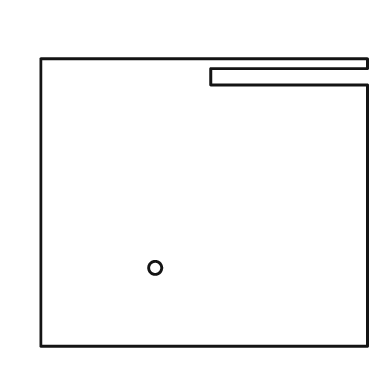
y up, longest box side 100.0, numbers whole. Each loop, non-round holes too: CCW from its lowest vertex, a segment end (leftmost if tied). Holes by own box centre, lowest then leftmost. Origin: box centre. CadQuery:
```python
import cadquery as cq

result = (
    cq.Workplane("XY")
    .moveTo(-50.0, -44.0)
    .lineTo(50.0, -44.0)
    .lineTo(50.0, 36.0)
    .lineTo(2.0, 36.0)
    .lineTo(2.0, 41.0)
    .lineTo(50.0, 41.0)
    .lineTo(50.0, 44.0)
    .lineTo(-50.0, 44.0)
    .close()
    .moveTo(-15.0, -20.0)
    .circle(2.0)
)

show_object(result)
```